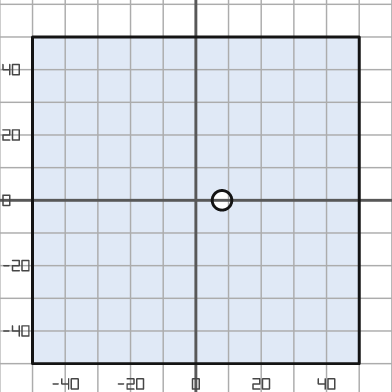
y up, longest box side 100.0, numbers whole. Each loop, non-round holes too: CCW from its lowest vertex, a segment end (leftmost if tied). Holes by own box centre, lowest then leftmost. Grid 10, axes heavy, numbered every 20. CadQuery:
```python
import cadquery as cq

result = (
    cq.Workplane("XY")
    .moveTo(-50.0, -50.0)
    .lineTo(50.0, -50.0)
    .lineTo(50.0, 50.0)
    .lineTo(-50.0, 50.0)
    .close()
    .moveTo(8.0, 0.0)
    .circle(3.0)
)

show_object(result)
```